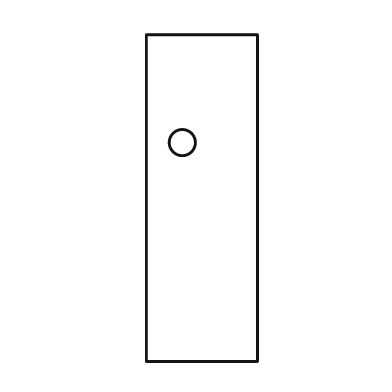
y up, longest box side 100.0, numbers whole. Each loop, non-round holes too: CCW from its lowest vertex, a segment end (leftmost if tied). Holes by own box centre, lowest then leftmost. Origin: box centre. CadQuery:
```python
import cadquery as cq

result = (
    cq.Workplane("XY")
    .moveTo(-17.0, -50.0)
    .lineTo(17.0, -50.0)
    .lineTo(17.0, 50.0)
    .lineTo(-17.0, 50.0)
    .close()
    .moveTo(-6.0, 17.0)
    .circle(4.0)
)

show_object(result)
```